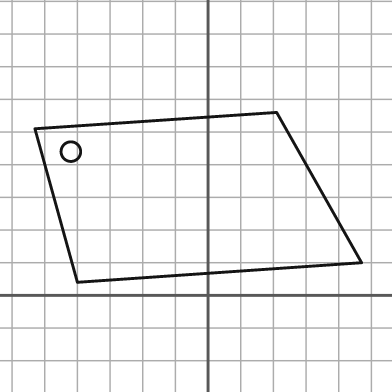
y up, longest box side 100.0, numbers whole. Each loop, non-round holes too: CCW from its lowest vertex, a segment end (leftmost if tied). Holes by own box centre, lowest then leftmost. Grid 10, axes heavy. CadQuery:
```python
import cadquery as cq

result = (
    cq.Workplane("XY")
    .moveTo(-40.0, 4.0)
    .lineTo(47.0, 10.0)
    .lineTo(21.0, 56.0)
    .lineTo(-53.0, 51.0)
    .close()
    .moveTo(-42.0, 44.0)
    .circle(3.0)
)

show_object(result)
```